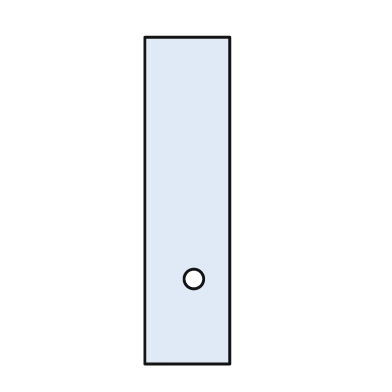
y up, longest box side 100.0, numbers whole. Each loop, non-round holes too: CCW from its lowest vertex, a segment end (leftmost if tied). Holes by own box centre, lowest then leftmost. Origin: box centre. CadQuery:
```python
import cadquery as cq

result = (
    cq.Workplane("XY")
    .moveTo(-13.0, -50.0)
    .lineTo(13.0, -50.0)
    .lineTo(13.0, 50.0)
    .lineTo(-13.0, 50.0)
    .close()
    .moveTo(2.0, -24.0)
    .circle(3.0)
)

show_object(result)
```